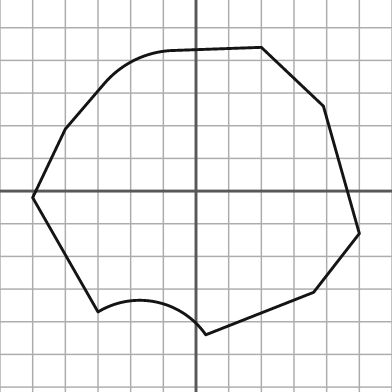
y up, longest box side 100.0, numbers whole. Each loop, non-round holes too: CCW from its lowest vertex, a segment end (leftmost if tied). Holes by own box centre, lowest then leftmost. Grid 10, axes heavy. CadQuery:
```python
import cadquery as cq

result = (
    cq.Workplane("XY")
    .moveTo(3.0, -44.0)
    .lineTo(36.0, -31.0)
    .lineTo(50.0, -13.0)
    .lineTo(39.0, 26.0)
    .lineTo(20.0, 44.0)
    .lineTo(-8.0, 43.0)
    .threePointArc((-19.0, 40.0), (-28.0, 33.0))
    .lineTo(-40.0, 19.0)
    .lineTo(-50.0, -2.0)
    .lineTo(-30.0, -37.0)
    .threePointArc((-12.0, -34.0), (3.0, -44.0))
    .close()
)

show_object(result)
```